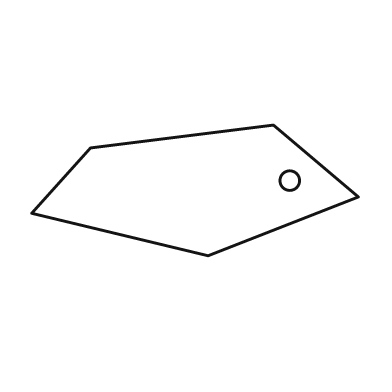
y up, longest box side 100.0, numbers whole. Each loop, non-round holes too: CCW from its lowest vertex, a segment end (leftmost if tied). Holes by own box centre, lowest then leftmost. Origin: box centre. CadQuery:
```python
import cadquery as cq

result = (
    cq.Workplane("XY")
    .moveTo(4.0, -20.0)
    .lineTo(50.0, -2.0)
    .lineTo(24.0, 20.0)
    .lineTo(-32.0, 13.0)
    .lineTo(-50.0, -7.0)
    .close()
    .moveTo(29.0, 3.0)
    .circle(3.0)
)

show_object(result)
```